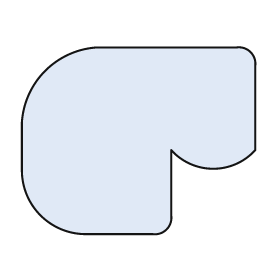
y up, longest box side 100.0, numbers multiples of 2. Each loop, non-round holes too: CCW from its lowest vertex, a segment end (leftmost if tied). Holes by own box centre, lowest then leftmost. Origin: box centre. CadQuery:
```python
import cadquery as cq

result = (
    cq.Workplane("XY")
    .moveTo(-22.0, -40.0)
    .lineTo(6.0, -40.0)
    .threePointArc((12.0, -38.0), (14.0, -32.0))
    .lineTo(14.0, -4.0)
    .threePointArc((32.0, -12.0), (50.0, -4.0))
    .lineTo(50.0, 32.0)
    .threePointArc((48.0, 38.0), (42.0, 40.0))
    .lineTo(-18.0, 40.0)
    .threePointArc((-40.0, 30.0), (-50.0, 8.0))
    .lineTo(-50.0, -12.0)
    .threePointArc((-42.0, -32.0), (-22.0, -40.0))
    .close()
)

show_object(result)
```